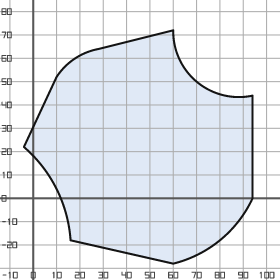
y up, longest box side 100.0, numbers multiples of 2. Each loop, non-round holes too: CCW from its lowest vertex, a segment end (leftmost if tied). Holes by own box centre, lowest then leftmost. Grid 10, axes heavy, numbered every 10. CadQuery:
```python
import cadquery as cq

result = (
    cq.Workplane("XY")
    .moveTo(60.0, -28.0)
    .threePointArc((80.0, -18.0), (94.0, 0.0))
    .lineTo(94.0, 44.0)
    .threePointArc((70.0, 50.0), (60.0, 72.0))
    .lineTo(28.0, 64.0)
    .threePointArc((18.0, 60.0), (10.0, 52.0))
    .lineTo(-4.0, 22.0)
    .threePointArc((10.0, 4.0), (16.0, -18.0))
    .close()
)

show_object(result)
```